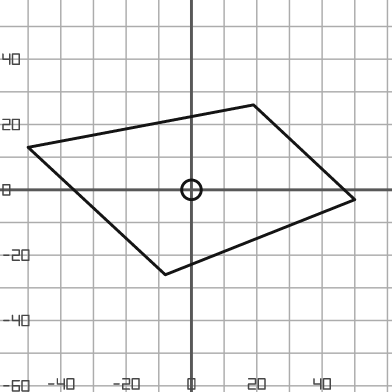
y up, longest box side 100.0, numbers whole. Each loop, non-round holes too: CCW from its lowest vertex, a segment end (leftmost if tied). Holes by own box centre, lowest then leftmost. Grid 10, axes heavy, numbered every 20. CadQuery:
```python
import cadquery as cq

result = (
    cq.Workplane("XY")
    .moveTo(-8.0, -26.0)
    .lineTo(50.0, -3.0)
    .lineTo(19.0, 26.0)
    .lineTo(-50.0, 13.0)
    .close()
    .moveTo(0.0, 0.0)
    .circle(3.0)
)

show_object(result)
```